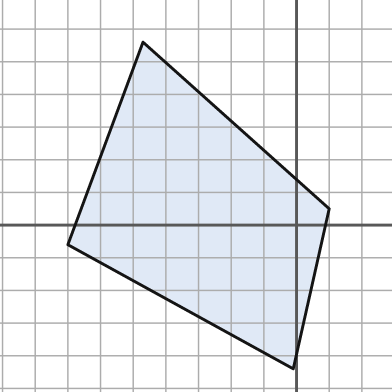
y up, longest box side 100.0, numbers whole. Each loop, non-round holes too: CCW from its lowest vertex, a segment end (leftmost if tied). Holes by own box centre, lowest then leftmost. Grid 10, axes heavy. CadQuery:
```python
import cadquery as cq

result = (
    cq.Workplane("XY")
    .moveTo(-1.0, -44.0)
    .lineTo(10.0, 5.0)
    .lineTo(-47.0, 56.0)
    .lineTo(-70.0, -6.0)
    .close()
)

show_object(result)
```